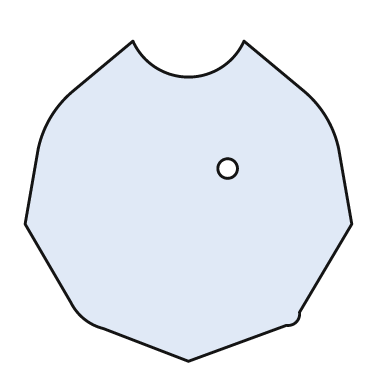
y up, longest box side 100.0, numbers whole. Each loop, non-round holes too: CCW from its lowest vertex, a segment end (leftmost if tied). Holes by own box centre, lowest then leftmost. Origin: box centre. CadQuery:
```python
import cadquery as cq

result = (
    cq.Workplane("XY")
    .moveTo(0.0, -49.0)
    .lineTo(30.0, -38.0)
    .threePointArc((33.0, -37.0), (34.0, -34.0))
    .lineTo(50.0, -7.0)
    .lineTo(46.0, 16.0)
    .threePointArc((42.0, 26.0), (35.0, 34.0))
    .lineTo(17.0, 49.0)
    .threePointArc((0.0, 38.0), (-17.0, 49.0))
    .lineTo(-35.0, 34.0)
    .threePointArc((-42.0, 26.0), (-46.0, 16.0))
    .lineTo(-50.0, -7.0)
    .lineTo(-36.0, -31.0)
    .threePointArc((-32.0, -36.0), (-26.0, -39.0))
    .close()
    .moveTo(12.0, 10.0)
    .circle(3.0)
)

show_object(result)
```